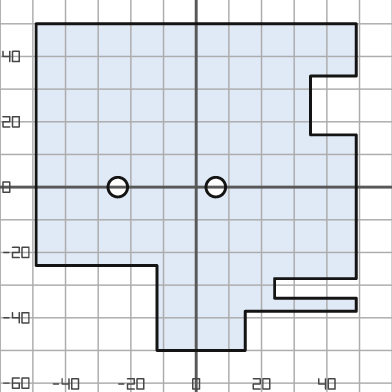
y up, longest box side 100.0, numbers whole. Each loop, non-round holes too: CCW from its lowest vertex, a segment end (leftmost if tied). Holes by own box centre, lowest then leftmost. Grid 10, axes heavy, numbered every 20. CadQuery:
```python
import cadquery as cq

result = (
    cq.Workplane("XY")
    .moveTo(-12.0, -50.0)
    .lineTo(15.0, -50.0)
    .lineTo(15.0, -38.0)
    .lineTo(49.0, -38.0)
    .lineTo(49.0, -34.0)
    .lineTo(24.0, -34.0)
    .lineTo(24.0, -28.0)
    .lineTo(49.0, -28.0)
    .lineTo(49.0, 16.0)
    .lineTo(35.0, 16.0)
    .lineTo(35.0, 34.0)
    .lineTo(49.0, 34.0)
    .lineTo(49.0, 50.0)
    .lineTo(-49.0, 50.0)
    .lineTo(-49.0, -24.0)
    .lineTo(-12.0, -24.0)
    .close()
    .moveTo(-24.0, 0.0)
    .circle(3.0)
    .moveTo(6.0, 0.0)
    .circle(3.0)
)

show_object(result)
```